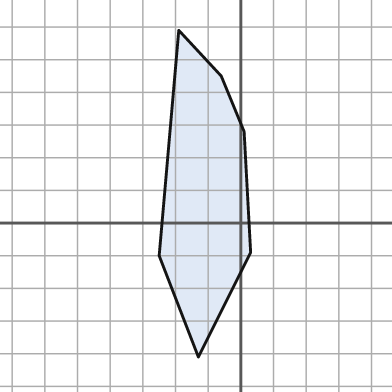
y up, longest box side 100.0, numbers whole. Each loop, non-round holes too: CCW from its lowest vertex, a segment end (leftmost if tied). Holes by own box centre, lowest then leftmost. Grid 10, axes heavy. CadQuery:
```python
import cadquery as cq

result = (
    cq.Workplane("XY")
    .moveTo(-13.0, -41.0)
    .lineTo(3.0, -9.0)
    .lineTo(1.0, 28.0)
    .lineTo(-6.0, 45.0)
    .lineTo(-19.0, 59.0)
    .lineTo(-25.0, -10.0)
    .close()
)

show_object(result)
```